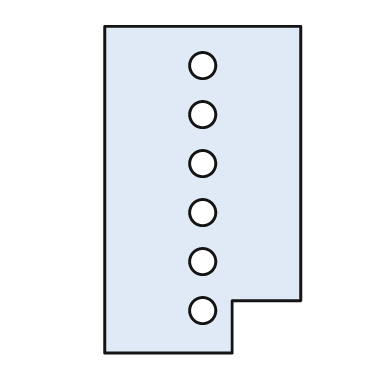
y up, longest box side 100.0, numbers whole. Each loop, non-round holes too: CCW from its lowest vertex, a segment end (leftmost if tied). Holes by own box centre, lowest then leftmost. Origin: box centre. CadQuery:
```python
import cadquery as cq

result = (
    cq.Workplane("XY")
    .moveTo(-30.0, -50.0)
    .lineTo(9.0, -50.0)
    .lineTo(9.0, -34.0)
    .lineTo(30.0, -34.0)
    .lineTo(30.0, 50.0)
    .lineTo(-30.0, 50.0)
    .close()
    .moveTo(0.0, -37.0)
    .circle(4.0)
    .moveTo(0.0, -22.0)
    .circle(4.0)
    .moveTo(0.0, -7.0)
    .circle(4.0)
    .moveTo(0.0, 8.0)
    .circle(4.0)
    .moveTo(0.0, 23.0)
    .circle(4.0)
    .moveTo(0.0, 38.0)
    .circle(4.0)
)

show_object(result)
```